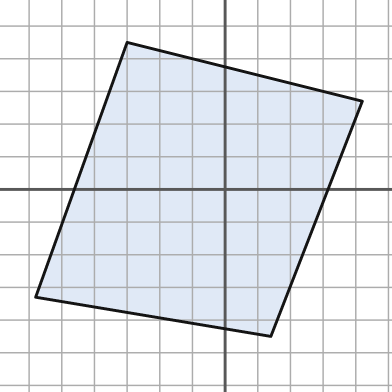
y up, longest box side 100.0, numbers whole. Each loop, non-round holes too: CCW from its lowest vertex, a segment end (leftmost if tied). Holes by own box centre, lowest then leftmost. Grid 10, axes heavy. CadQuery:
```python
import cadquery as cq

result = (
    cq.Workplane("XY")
    .moveTo(14.0, -45.0)
    .lineTo(42.0, 27.0)
    .lineTo(-30.0, 45.0)
    .lineTo(-58.0, -33.0)
    .close()
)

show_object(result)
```